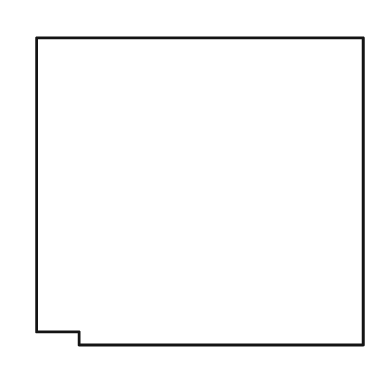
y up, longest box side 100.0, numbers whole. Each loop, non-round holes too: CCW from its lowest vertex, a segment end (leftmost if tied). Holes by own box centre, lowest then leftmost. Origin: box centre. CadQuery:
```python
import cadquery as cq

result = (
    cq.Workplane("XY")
    .moveTo(-37.0, -47.0)
    .lineTo(50.0, -47.0)
    .lineTo(50.0, 47.0)
    .lineTo(-50.0, 47.0)
    .lineTo(-50.0, -43.0)
    .lineTo(-37.0, -43.0)
    .close()
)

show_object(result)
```